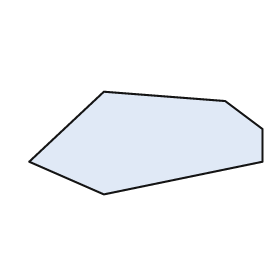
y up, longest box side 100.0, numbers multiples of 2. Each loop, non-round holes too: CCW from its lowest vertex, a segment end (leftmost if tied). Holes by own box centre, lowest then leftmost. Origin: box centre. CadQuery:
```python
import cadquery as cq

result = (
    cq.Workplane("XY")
    .moveTo(-18.0, -22.0)
    .lineTo(50.0, -8.0)
    .lineTo(50.0, 6.0)
    .lineTo(34.0, 18.0)
    .lineTo(-18.0, 22.0)
    .lineTo(-50.0, -8.0)
    .close()
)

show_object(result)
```